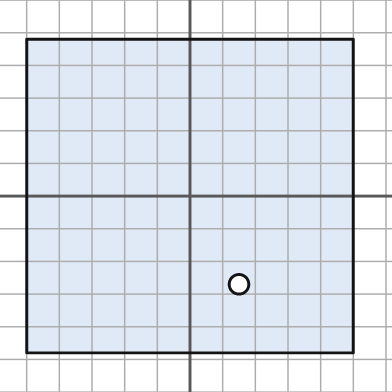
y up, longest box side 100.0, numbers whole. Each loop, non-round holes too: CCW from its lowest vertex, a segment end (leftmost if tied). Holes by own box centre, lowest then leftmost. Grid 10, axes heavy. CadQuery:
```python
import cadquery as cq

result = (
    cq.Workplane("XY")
    .moveTo(-50.0, -48.0)
    .lineTo(50.0, -48.0)
    .lineTo(50.0, 48.0)
    .lineTo(-50.0, 48.0)
    .close()
    .moveTo(15.0, -27.0)
    .circle(3.0)
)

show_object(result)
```